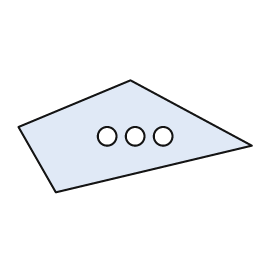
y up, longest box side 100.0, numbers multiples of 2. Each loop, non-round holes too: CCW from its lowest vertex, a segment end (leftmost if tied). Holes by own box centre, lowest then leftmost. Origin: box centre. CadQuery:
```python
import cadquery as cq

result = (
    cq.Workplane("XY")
    .moveTo(-34.0, -24.0)
    .lineTo(50.0, -4.0)
    .lineTo(-2.0, 24.0)
    .lineTo(-50.0, 4.0)
    .close()
    .moveTo(-12.0, 0.0)
    .circle(4.0)
    .moveTo(0.0, 0.0)
    .circle(4.0)
    .moveTo(12.0, 0.0)
    .circle(4.0)
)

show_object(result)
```